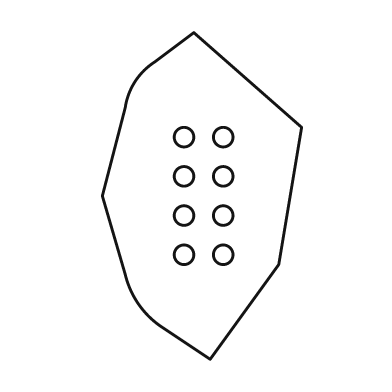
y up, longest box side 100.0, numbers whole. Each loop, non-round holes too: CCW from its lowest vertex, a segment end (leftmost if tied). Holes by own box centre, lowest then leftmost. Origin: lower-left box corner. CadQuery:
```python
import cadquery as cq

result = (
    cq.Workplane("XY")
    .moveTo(33.0, 0.0)
    .lineTo(54.0, 29.0)
    .lineTo(61.0, 71.0)
    .lineTo(28.0, 100.0)
    .lineTo(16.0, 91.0)
    .threePointArc((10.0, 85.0), (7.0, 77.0))
    .lineTo(0.0, 50.0)
    .lineTo(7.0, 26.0)
    .threePointArc((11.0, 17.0), (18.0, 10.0))
    .close()
    .moveTo(25.0, 32.0)
    .circle(3.0)
    .moveTo(37.0, 32.0)
    .circle(3.0)
    .moveTo(25.0, 44.0)
    .circle(3.0)
    .moveTo(37.0, 44.0)
    .circle(3.0)
    .moveTo(25.0, 56.0)
    .circle(3.0)
    .moveTo(37.0, 56.0)
    .circle(3.0)
    .moveTo(25.0, 68.0)
    .circle(3.0)
    .moveTo(37.0, 68.0)
    .circle(3.0)
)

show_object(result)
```